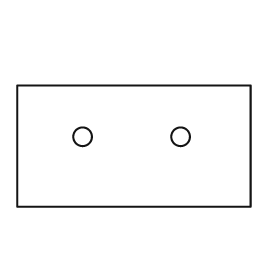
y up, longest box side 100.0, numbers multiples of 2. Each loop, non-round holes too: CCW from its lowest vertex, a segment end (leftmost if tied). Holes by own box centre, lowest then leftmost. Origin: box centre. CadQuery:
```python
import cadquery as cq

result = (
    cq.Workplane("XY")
    .moveTo(-50.0, -26.0)
    .lineTo(50.0, -26.0)
    .lineTo(50.0, 26.0)
    .lineTo(-50.0, 26.0)
    .close()
    .moveTo(-22.0, 4.0)
    .circle(4.0)
    .moveTo(20.0, 4.0)
    .circle(4.0)
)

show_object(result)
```